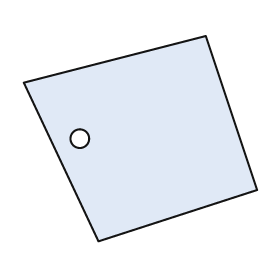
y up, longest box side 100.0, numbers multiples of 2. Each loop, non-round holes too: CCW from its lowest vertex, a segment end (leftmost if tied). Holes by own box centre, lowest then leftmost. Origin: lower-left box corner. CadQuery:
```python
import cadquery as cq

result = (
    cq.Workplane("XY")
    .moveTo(32.0, 0.0)
    .lineTo(100.0, 22.0)
    .lineTo(78.0, 88.0)
    .lineTo(0.0, 68.0)
    .close()
    .moveTo(24.0, 44.0)
    .circle(4.0)
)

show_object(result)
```